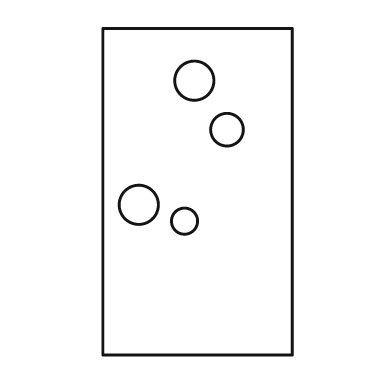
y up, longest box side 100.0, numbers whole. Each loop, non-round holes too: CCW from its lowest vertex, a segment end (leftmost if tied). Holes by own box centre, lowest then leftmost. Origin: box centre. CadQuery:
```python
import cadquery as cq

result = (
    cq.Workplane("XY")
    .moveTo(-29.0, -50.0)
    .lineTo(29.0, -50.0)
    .lineTo(29.0, 50.0)
    .lineTo(-29.0, 50.0)
    .close()
    .moveTo(-4.0, -9.0)
    .circle(4.0)
    .moveTo(-18.0, -4.0)
    .circle(6.0)
    .moveTo(9.0, 19.0)
    .circle(5.0)
    .moveTo(-1.0, 34.0)
    .circle(6.0)
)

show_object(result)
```